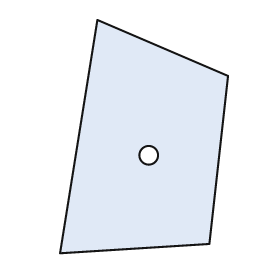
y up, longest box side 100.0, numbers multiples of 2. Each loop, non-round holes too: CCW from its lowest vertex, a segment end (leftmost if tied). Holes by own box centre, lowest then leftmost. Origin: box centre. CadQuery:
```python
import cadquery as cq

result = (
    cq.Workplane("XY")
    .moveTo(-36.0, -50.0)
    .lineTo(28.0, -46.0)
    .lineTo(36.0, 26.0)
    .lineTo(-20.0, 50.0)
    .close()
    .moveTo(2.0, -8.0)
    .circle(4.0)
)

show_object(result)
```